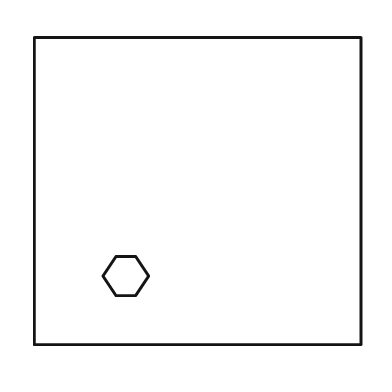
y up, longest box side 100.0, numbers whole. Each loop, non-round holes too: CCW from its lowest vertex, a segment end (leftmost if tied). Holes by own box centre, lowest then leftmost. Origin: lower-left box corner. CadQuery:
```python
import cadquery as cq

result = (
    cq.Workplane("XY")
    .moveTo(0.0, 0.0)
    .lineTo(100.0, 0.0)
    .lineTo(100.0, 94.0)
    .lineTo(0.0, 94.0)
    .close()
    .moveTo(25.0, 15.0)
    .lineTo(31.0, 15.0)
    .lineTo(35.0, 21.0)
    .lineTo(31.0, 27.0)
    .lineTo(25.0, 27.0)
    .lineTo(21.0, 21.0)
    .close()
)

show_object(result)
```